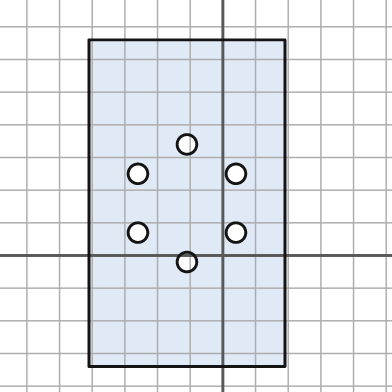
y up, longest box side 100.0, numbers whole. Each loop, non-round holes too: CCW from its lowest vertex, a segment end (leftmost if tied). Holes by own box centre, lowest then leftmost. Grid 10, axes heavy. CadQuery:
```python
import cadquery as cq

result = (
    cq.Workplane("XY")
    .moveTo(-41.0, -34.0)
    .lineTo(19.0, -34.0)
    .lineTo(19.0, 66.0)
    .lineTo(-41.0, 66.0)
    .close()
    .moveTo(-11.0, -2.0)
    .circle(3.0)
    .moveTo(-26.0, 7.0)
    .circle(3.0)
    .moveTo(4.0, 7.0)
    .circle(3.0)
    .moveTo(-26.0, 25.0)
    .circle(3.0)
    .moveTo(4.0, 25.0)
    .circle(3.0)
    .moveTo(-11.0, 34.0)
    .circle(3.0)
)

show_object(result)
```